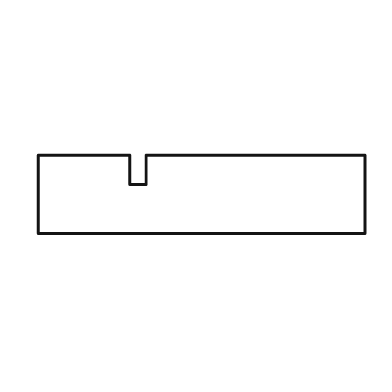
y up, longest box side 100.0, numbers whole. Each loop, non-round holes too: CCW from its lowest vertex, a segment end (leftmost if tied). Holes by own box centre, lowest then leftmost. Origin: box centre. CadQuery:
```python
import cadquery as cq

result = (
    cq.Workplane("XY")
    .moveTo(-50.0, -12.0)
    .lineTo(50.0, -12.0)
    .lineTo(50.0, 12.0)
    .lineTo(-17.0, 12.0)
    .lineTo(-17.0, 3.0)
    .lineTo(-22.0, 3.0)
    .lineTo(-22.0, 12.0)
    .lineTo(-50.0, 12.0)
    .close()
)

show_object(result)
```